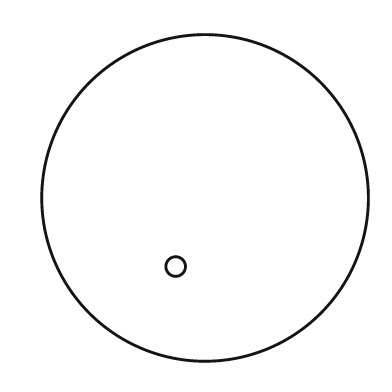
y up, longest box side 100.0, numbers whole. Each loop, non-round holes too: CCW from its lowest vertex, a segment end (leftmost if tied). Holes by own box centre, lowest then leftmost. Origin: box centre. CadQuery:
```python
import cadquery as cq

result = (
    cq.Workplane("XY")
    .moveTo(0.0, 0.0)
    .circle(50.0)
    .moveTo(-9.0, -21.0)
    .circle(3.0)
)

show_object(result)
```